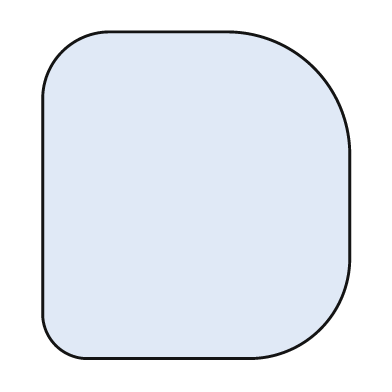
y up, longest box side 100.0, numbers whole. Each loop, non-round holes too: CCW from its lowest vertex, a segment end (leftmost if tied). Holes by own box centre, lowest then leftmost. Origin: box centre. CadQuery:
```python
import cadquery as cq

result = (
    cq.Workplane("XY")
    .moveTo(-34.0, -50.0)
    .lineTo(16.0, -50.0)
    .threePointArc((38.0, -41.0), (47.0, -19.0))
    .lineTo(47.0, 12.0)
    .threePointArc((36.0, 39.0), (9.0, 50.0))
    .lineTo(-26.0, 50.0)
    .threePointArc((-41.0, 44.0), (-47.0, 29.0))
    .lineTo(-47.0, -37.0)
    .threePointArc((-43.0, -46.0), (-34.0, -50.0))
    .close()
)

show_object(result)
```